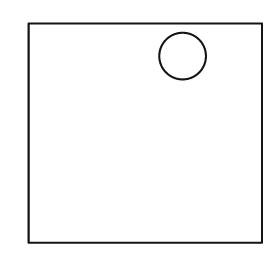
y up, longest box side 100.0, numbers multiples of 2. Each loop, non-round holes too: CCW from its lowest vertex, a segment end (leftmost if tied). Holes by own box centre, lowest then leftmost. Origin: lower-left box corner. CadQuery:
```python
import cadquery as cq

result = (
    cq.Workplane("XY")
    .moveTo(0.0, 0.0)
    .lineTo(100.0, 0.0)
    .lineTo(100.0, 94.0)
    .lineTo(0.0, 94.0)
    .close()
    .moveTo(66.0, 80.0)
    .circle(10.0)
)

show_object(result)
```